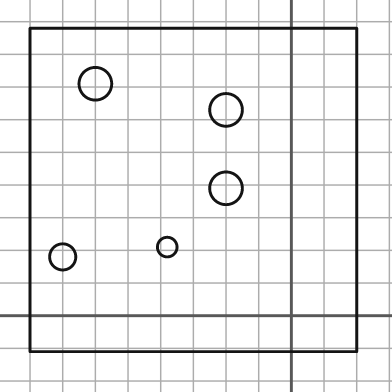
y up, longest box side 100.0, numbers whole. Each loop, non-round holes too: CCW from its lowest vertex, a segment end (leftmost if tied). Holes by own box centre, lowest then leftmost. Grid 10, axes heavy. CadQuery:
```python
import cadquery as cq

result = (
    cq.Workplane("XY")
    .moveTo(-80.0, -11.0)
    .lineTo(20.0, -11.0)
    .lineTo(20.0, 88.0)
    .lineTo(-80.0, 88.0)
    .close()
    .moveTo(-70.0, 18.0)
    .circle(4.0)
    .moveTo(-38.0, 21.0)
    .circle(3.0)
    .moveTo(-20.0, 39.0)
    .circle(5.0)
    .moveTo(-20.0, 63.0)
    .circle(5.0)
    .moveTo(-60.0, 71.0)
    .circle(5.0)
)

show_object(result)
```